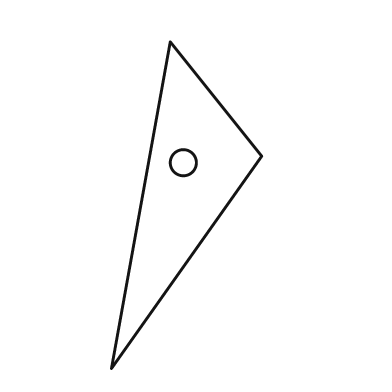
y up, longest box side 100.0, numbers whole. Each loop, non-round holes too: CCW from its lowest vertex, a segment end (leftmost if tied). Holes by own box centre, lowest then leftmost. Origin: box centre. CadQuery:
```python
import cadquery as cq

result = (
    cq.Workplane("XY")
    .moveTo(-23.0, -50.0)
    .lineTo(23.0, 15.0)
    .lineTo(-5.0, 50.0)
    .close()
    .moveTo(-1.0, 13.0)
    .circle(4.0)
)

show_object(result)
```